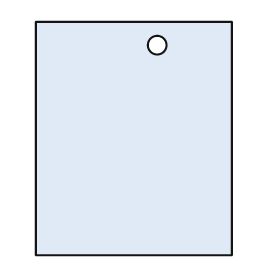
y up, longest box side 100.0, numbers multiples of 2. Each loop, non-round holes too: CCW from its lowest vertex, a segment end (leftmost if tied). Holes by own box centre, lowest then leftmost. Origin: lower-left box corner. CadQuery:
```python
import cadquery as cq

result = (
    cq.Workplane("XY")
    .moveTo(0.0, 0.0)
    .lineTo(84.0, 0.0)
    .lineTo(84.0, 100.0)
    .lineTo(0.0, 100.0)
    .close()
    .moveTo(52.0, 90.0)
    .circle(4.0)
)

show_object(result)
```